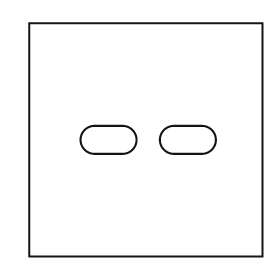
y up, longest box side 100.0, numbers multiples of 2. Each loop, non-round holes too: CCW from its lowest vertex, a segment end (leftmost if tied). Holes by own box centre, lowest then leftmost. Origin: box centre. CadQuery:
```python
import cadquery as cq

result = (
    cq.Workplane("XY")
    .moveTo(-50.0, -50.0)
    .lineTo(50.0, -50.0)
    .lineTo(50.0, 50.0)
    .lineTo(-50.0, 50.0)
    .close()
    .moveTo(-22.0, -6.0)
    .lineTo(-10.0, -6.0)
    .threePointArc((-4.0, 0.0), (-10.0, 6.0))
    .lineTo(-22.0, 6.0)
    .threePointArc((-28.0, 0.0), (-22.0, -6.0))
    .close()
    .moveTo(12.0, -6.0)
    .lineTo(24.0, -6.0)
    .threePointArc((30.0, 0.0), (24.0, 6.0))
    .lineTo(12.0, 6.0)
    .threePointArc((6.0, 0.0), (12.0, -6.0))
    .close()
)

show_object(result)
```